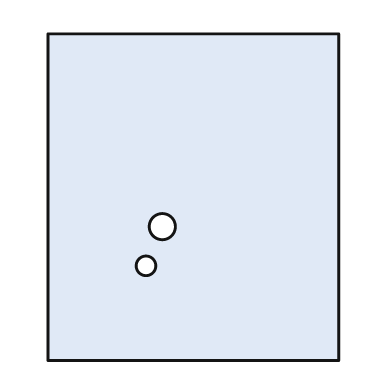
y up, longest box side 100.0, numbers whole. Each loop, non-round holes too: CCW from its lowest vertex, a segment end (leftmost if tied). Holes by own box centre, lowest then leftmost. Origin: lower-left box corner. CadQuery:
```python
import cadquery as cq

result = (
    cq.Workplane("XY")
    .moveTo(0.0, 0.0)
    .lineTo(89.0, 0.0)
    .lineTo(89.0, 100.0)
    .lineTo(0.0, 100.0)
    .close()
    .moveTo(30.0, 29.0)
    .circle(3.0)
    .moveTo(35.0, 41.0)
    .circle(4.0)
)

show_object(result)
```